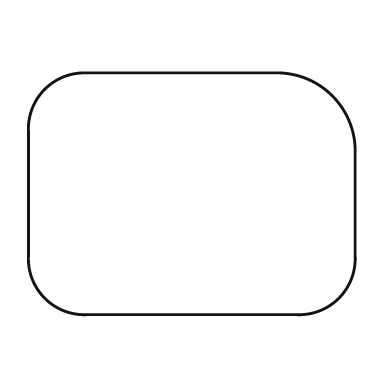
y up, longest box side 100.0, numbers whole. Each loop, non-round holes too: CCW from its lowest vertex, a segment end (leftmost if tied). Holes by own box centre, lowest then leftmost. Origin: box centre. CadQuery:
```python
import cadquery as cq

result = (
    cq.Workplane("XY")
    .moveTo(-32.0, -37.0)
    .lineTo(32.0, -37.0)
    .threePointArc((45.0, -32.0), (50.0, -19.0))
    .lineTo(50.0, 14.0)
    .threePointArc((43.0, 30.0), (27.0, 37.0))
    .lineTo(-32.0, 37.0)
    .threePointArc((-45.0, 32.0), (-50.0, 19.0))
    .lineTo(-50.0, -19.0)
    .threePointArc((-45.0, -32.0), (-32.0, -37.0))
    .close()
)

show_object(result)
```